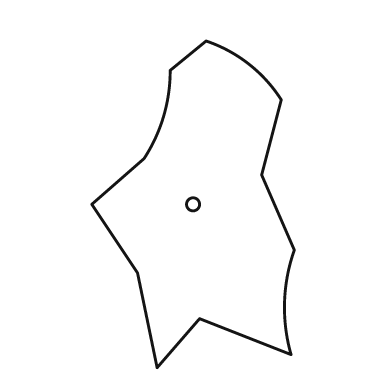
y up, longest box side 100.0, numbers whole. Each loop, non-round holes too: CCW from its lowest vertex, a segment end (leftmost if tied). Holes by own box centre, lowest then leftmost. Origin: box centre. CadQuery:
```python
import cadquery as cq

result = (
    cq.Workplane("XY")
    .moveTo(-11.0, -50.0)
    .lineTo(2.0, -35.0)
    .lineTo(30.0, -46.0)
    .threePointArc((28.0, -30.0), (31.0, -14.0))
    .lineTo(21.0, 9.0)
    .lineTo(27.0, 32.0)
    .threePointArc((17.0, 43.0), (4.0, 50.0))
    .lineTo(-7.0, 41.0)
    .threePointArc((-9.0, 27.0), (-15.0, 14.0))
    .lineTo(-31.0, 0.0)
    .lineTo(-17.0, -21.0)
    .close()
    .moveTo(0.0, 0.0)
    .circle(2.0)
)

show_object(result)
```